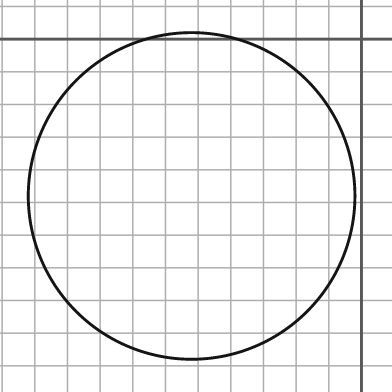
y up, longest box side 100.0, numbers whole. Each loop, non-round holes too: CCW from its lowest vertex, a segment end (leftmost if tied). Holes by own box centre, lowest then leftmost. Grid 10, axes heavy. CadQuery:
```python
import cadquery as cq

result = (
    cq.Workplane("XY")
    .moveTo(-52.0, -48.0)
    .circle(50.0)
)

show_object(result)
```